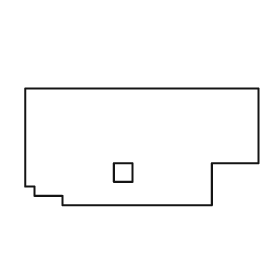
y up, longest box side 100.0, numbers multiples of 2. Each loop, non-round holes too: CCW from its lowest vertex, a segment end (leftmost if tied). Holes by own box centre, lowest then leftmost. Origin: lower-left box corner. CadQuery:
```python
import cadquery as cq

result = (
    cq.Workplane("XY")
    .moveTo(16.0, 0.0)
    .lineTo(80.0, 0.0)
    .lineTo(80.0, 18.0)
    .lineTo(100.0, 18.0)
    .lineTo(100.0, 50.0)
    .lineTo(0.0, 50.0)
    .lineTo(0.0, 8.0)
    .lineTo(4.0, 8.0)
    .lineTo(4.0, 4.0)
    .lineTo(16.0, 4.0)
    .close()
    .moveTo(38.0, 10.0)
    .lineTo(46.0, 10.0)
    .lineTo(46.0, 18.0)
    .lineTo(38.0, 18.0)
    .close()
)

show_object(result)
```